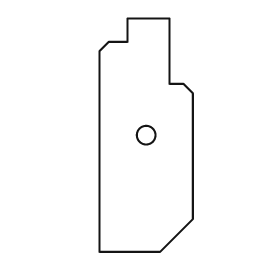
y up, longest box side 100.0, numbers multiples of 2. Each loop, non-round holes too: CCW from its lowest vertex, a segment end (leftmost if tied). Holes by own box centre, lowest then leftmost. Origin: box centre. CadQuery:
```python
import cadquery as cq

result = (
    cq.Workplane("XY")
    .moveTo(-20.0, -50.0)
    .lineTo(6.0, -50.0)
    .lineTo(20.0, -36.0)
    .lineTo(20.0, 18.0)
    .lineTo(16.0, 22.0)
    .lineTo(10.0, 22.0)
    .lineTo(10.0, 50.0)
    .lineTo(-8.0, 50.0)
    .lineTo(-8.0, 40.0)
    .lineTo(-16.0, 40.0)
    .lineTo(-20.0, 36.0)
    .close()
    .moveTo(0.0, 0.0)
    .circle(4.0)
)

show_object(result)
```